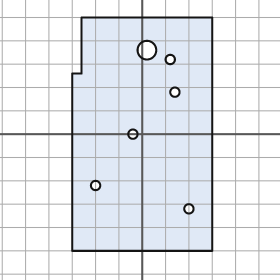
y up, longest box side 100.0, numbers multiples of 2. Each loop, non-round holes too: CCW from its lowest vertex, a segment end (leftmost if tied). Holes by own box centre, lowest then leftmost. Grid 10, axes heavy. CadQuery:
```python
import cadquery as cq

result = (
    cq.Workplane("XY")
    .moveTo(-30.0, -50.0)
    .lineTo(30.0, -50.0)
    .lineTo(30.0, 50.0)
    .lineTo(-26.0, 50.0)
    .lineTo(-26.0, 26.0)
    .lineTo(-30.0, 26.0)
    .close()
    .moveTo(20.0, -32.0)
    .circle(2.0)
    .moveTo(-20.0, -22.0)
    .circle(2.0)
    .moveTo(-4.0, 0.0)
    .circle(2.0)
    .moveTo(14.0, 18.0)
    .circle(2.0)
    .moveTo(12.0, 32.0)
    .circle(2.0)
    .moveTo(2.0, 36.0)
    .circle(4.0)
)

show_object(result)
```